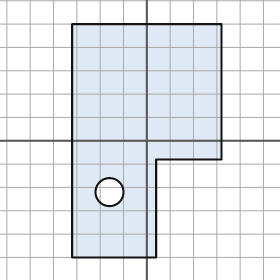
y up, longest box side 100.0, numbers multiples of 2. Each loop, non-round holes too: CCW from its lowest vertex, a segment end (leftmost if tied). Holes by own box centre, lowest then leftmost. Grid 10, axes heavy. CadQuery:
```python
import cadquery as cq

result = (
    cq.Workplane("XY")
    .moveTo(-32.0, -50.0)
    .lineTo(4.0, -50.0)
    .lineTo(4.0, -8.0)
    .lineTo(32.0, -8.0)
    .lineTo(32.0, 50.0)
    .lineTo(-32.0, 50.0)
    .close()
    .moveTo(-16.0, -22.0)
    .circle(6.0)
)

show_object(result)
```